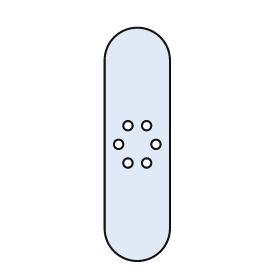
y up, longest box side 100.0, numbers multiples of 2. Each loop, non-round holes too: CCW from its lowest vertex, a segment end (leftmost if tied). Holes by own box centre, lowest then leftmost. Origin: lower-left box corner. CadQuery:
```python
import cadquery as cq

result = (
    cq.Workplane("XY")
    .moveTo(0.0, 14.0)
    .threePointArc((14.0, 0.0), (28.0, 14.0))
    .lineTo(28.0, 86.0)
    .threePointArc((14.0, 100.0), (0.0, 86.0))
    .close()
    .moveTo(10.0, 42.0)
    .circle(2.0)
    .moveTo(18.0, 42.0)
    .circle(2.0)
    .moveTo(6.0, 50.0)
    .circle(2.0)
    .moveTo(22.0, 50.0)
    .circle(2.0)
    .moveTo(10.0, 58.0)
    .circle(2.0)
    .moveTo(18.0, 58.0)
    .circle(2.0)
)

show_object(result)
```